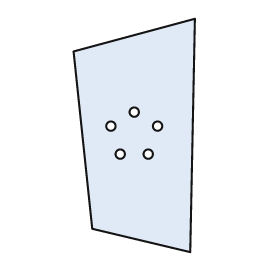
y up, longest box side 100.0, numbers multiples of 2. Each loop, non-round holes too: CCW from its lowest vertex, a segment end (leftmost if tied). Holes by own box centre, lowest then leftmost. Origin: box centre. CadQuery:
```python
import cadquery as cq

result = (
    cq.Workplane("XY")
    .moveTo(24.0, -50.0)
    .lineTo(26.0, 50.0)
    .lineTo(-26.0, 36.0)
    .lineTo(-18.0, -40.0)
    .close()
    .moveTo(-6.0, -8.0)
    .circle(2.0)
    .moveTo(6.0, -8.0)
    .circle(2.0)
    .moveTo(-10.0, 4.0)
    .circle(2.0)
    .moveTo(10.0, 4.0)
    .circle(2.0)
    .moveTo(0.0, 10.0)
    .circle(2.0)
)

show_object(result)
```